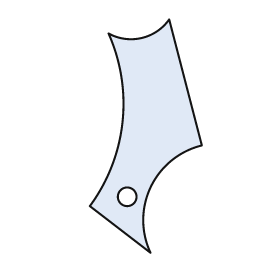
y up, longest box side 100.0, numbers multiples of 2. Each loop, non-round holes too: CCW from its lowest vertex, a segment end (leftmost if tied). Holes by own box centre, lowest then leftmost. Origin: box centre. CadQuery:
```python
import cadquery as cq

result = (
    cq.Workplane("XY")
    .moveTo(2.0, -50.0)
    .threePointArc((2.0, -22.0), (24.0, -4.0))
    .lineTo(10.0, 50.0)
    .threePointArc((-2.0, 42.0), (-16.0, 44.0))
    .threePointArc((-10.0, 6.0), (-24.0, -30.0))
    .close()
    .moveTo(-8.0, -26.0)
    .circle(4.0)
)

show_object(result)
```